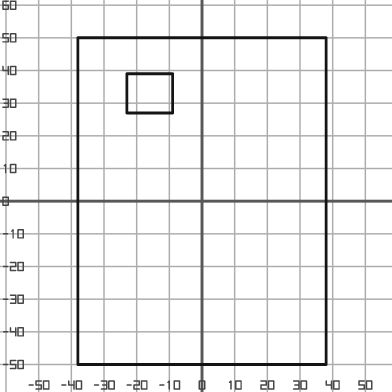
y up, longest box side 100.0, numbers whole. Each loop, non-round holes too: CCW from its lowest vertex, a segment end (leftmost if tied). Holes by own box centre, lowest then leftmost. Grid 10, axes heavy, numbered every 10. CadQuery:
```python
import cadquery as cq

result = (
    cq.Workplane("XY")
    .moveTo(-38.0, -50.0)
    .lineTo(38.0, -50.0)
    .lineTo(38.0, 50.0)
    .lineTo(-38.0, 50.0)
    .close()
    .moveTo(-23.0, 27.0)
    .lineTo(-9.0, 27.0)
    .lineTo(-9.0, 39.0)
    .lineTo(-23.0, 39.0)
    .close()
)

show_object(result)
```